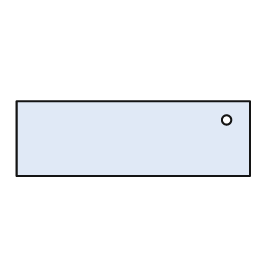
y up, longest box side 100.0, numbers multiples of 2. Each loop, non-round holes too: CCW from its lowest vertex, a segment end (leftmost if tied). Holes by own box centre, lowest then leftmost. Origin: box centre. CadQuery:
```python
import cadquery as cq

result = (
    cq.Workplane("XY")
    .moveTo(-50.0, -16.0)
    .lineTo(50.0, -16.0)
    .lineTo(50.0, 16.0)
    .lineTo(-50.0, 16.0)
    .close()
    .moveTo(40.0, 8.0)
    .circle(2.0)
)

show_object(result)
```